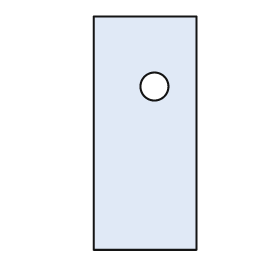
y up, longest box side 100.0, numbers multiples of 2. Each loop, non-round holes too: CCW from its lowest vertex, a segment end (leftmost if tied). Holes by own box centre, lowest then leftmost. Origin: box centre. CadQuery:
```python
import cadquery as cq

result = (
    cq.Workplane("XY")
    .moveTo(-22.0, -50.0)
    .lineTo(22.0, -50.0)
    .lineTo(22.0, 50.0)
    .lineTo(-22.0, 50.0)
    .close()
    .moveTo(4.0, 20.0)
    .circle(6.0)
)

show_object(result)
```